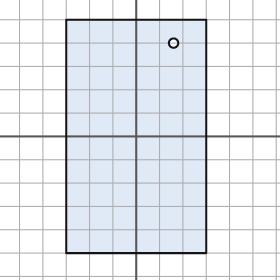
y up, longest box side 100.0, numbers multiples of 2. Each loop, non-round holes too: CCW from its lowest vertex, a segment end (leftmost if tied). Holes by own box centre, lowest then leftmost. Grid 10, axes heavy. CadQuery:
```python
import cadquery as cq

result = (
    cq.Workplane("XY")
    .moveTo(-30.0, -50.0)
    .lineTo(30.0, -50.0)
    .lineTo(30.0, 50.0)
    .lineTo(-30.0, 50.0)
    .close()
    .moveTo(16.0, 40.0)
    .circle(2.0)
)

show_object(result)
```